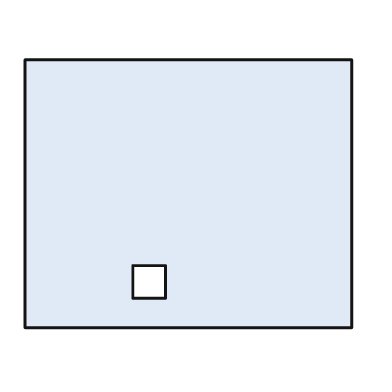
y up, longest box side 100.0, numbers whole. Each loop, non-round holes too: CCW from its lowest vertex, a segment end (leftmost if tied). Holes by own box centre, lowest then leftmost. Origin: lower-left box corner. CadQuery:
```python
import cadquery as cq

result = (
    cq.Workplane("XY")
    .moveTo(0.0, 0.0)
    .lineTo(100.0, 0.0)
    .lineTo(100.0, 82.0)
    .lineTo(0.0, 82.0)
    .close()
    .moveTo(33.0, 9.0)
    .lineTo(43.0, 9.0)
    .lineTo(43.0, 19.0)
    .lineTo(33.0, 19.0)
    .close()
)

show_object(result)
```